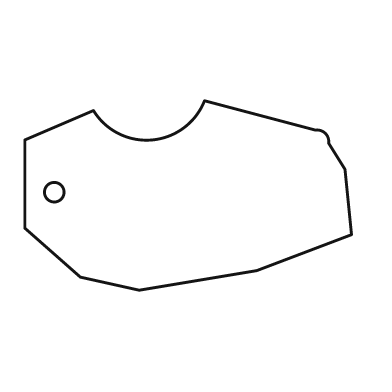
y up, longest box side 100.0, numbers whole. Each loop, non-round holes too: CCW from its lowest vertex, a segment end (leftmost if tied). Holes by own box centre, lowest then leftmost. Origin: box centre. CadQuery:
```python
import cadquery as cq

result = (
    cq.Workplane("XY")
    .moveTo(-15.0, -29.0)
    .lineTo(21.0, -23.0)
    .lineTo(50.0, -12.0)
    .lineTo(48.0, 8.0)
    .lineTo(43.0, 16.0)
    .threePointArc((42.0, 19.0), (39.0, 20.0))
    .lineTo(5.0, 29.0)
    .threePointArc((-11.0, 17.0), (-29.0, 26.0))
    .lineTo(-50.0, 17.0)
    .lineTo(-50.0, -10.0)
    .lineTo(-33.0, -25.0)
    .close()
    .moveTo(-41.0, 1.0)
    .circle(3.0)
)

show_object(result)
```